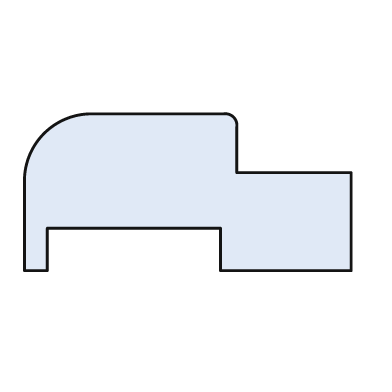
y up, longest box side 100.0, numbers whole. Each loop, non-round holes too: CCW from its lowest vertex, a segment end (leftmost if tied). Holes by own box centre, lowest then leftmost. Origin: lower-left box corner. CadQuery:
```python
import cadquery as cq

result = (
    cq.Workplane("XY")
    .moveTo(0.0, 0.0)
    .lineTo(7.0, 0.0)
    .lineTo(7.0, 13.0)
    .lineTo(60.0, 13.0)
    .lineTo(60.0, 0.0)
    .lineTo(100.0, 0.0)
    .lineTo(100.0, 30.0)
    .lineTo(65.0, 30.0)
    .lineTo(65.0, 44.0)
    .threePointArc((64.0, 47.0), (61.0, 48.0))
    .lineTo(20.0, 48.0)
    .threePointArc((6.0, 42.0), (0.0, 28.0))
    .close()
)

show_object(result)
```